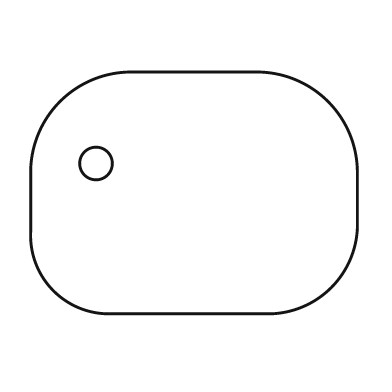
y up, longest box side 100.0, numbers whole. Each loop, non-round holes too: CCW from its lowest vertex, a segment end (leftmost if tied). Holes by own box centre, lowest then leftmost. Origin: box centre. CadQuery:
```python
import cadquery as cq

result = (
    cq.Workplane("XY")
    .moveTo(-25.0, -37.0)
    .lineTo(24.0, -37.0)
    .threePointArc((42.0, -29.0), (50.0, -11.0))
    .lineTo(50.0, 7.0)
    .threePointArc((41.0, 28.0), (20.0, 37.0))
    .lineTo(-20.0, 37.0)
    .threePointArc((-41.0, 28.0), (-50.0, 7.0))
    .lineTo(-50.0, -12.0)
    .threePointArc((-43.0, -30.0), (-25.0, -37.0))
    .close()
    .moveTo(-30.0, 9.0)
    .circle(5.0)
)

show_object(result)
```